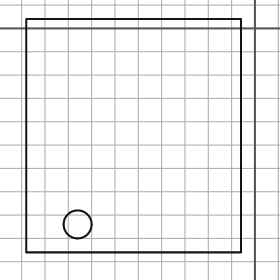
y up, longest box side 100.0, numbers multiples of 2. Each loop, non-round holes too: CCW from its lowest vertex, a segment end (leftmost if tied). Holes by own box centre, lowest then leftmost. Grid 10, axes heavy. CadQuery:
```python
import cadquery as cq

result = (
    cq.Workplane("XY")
    .moveTo(-98.0, -96.0)
    .lineTo(-6.0, -96.0)
    .lineTo(-6.0, 4.0)
    .lineTo(-98.0, 4.0)
    .close()
    .moveTo(-76.0, -84.0)
    .circle(6.0)
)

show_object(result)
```